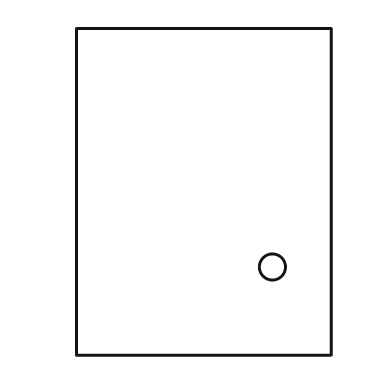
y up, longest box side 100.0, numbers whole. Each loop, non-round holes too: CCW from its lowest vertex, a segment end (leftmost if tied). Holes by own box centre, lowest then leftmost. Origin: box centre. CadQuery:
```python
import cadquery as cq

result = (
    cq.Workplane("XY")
    .moveTo(-39.0, -50.0)
    .lineTo(39.0, -50.0)
    .lineTo(39.0, 50.0)
    .lineTo(-39.0, 50.0)
    .close()
    .moveTo(21.0, -23.0)
    .circle(4.0)
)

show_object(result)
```